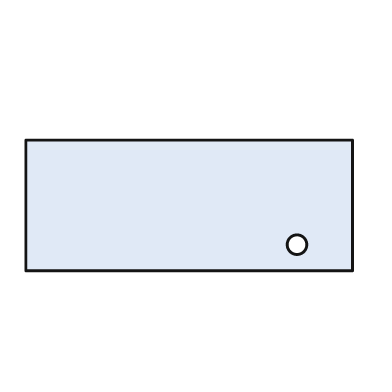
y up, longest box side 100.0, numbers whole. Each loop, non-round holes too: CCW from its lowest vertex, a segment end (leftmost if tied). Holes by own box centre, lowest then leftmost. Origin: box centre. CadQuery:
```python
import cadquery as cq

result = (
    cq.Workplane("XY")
    .moveTo(-50.0, -20.0)
    .lineTo(50.0, -20.0)
    .lineTo(50.0, 20.0)
    .lineTo(-50.0, 20.0)
    .close()
    .moveTo(33.0, -12.0)
    .circle(3.0)
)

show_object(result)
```